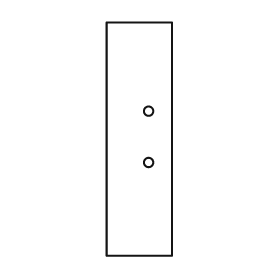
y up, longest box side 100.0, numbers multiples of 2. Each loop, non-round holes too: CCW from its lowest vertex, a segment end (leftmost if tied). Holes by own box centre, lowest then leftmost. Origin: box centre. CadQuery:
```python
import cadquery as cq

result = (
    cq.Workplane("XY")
    .moveTo(-14.0, -50.0)
    .lineTo(14.0, -50.0)
    .lineTo(14.0, 50.0)
    .lineTo(-14.0, 50.0)
    .close()
    .moveTo(4.0, -10.0)
    .circle(2.0)
    .moveTo(4.0, 12.0)
    .circle(2.0)
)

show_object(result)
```